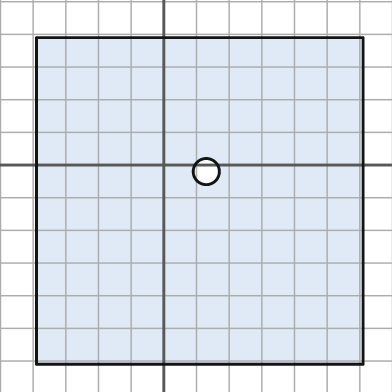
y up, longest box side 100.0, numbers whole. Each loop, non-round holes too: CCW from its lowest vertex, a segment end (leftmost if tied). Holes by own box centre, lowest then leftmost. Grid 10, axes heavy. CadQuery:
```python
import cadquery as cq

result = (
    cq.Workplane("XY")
    .moveTo(-39.0, -61.0)
    .lineTo(61.0, -61.0)
    .lineTo(61.0, 39.0)
    .lineTo(-39.0, 39.0)
    .close()
    .moveTo(13.0, -2.0)
    .circle(4.0)
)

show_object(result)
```